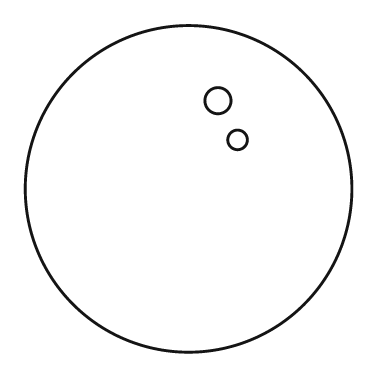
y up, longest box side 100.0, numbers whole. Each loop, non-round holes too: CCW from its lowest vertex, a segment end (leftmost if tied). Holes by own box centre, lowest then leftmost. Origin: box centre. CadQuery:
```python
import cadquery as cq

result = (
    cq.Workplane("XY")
    .moveTo(0.0, 0.0)
    .circle(50.0)
    .moveTo(15.0, 15.0)
    .circle(3.0)
    .moveTo(9.0, 27.0)
    .circle(4.0)
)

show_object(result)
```